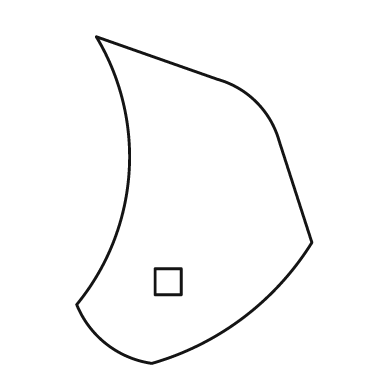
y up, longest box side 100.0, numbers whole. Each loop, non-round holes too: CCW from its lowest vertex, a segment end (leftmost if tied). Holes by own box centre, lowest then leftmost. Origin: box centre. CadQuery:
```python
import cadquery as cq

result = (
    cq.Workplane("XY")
    .moveTo(-13.0, -50.0)
    .threePointArc((15.0, -36.0), (36.0, -13.0))
    .lineTo(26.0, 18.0)
    .threePointArc((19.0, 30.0), (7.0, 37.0))
    .lineTo(-30.0, 50.0)
    .threePointArc((-20.0, 8.0), (-36.0, -32.0))
    .threePointArc((-27.0, -44.0), (-13.0, -50.0))
    .close()
    .moveTo(-12.0, -29.0)
    .lineTo(-4.0, -29.0)
    .lineTo(-4.0, -21.0)
    .lineTo(-12.0, -21.0)
    .close()
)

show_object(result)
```